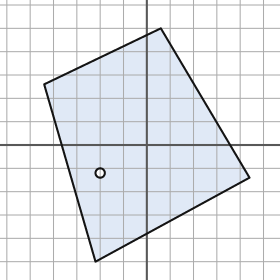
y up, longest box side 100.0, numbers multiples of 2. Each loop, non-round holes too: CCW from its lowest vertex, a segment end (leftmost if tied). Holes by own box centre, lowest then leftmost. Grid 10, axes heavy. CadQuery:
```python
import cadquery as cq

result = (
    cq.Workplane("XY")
    .moveTo(-22.0, -50.0)
    .lineTo(44.0, -14.0)
    .lineTo(6.0, 50.0)
    .lineTo(-44.0, 26.0)
    .close()
    .moveTo(-20.0, -12.0)
    .circle(2.0)
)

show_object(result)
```